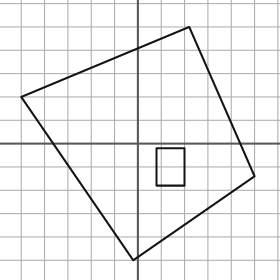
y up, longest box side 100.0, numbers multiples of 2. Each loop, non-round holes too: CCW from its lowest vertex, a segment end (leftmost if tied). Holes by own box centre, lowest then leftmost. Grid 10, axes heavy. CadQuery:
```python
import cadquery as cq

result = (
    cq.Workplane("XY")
    .moveTo(-2.0, -50.0)
    .lineTo(50.0, -14.0)
    .lineTo(22.0, 50.0)
    .lineTo(-50.0, 20.0)
    .close()
    .moveTo(8.0, -18.0)
    .lineTo(20.0, -18.0)
    .lineTo(20.0, -2.0)
    .lineTo(8.0, -2.0)
    .close()
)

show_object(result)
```